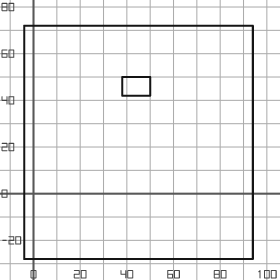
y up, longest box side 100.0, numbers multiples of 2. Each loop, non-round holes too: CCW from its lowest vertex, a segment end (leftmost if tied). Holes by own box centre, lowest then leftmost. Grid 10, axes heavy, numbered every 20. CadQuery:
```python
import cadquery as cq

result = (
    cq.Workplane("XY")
    .moveTo(-4.0, -28.0)
    .lineTo(94.0, -28.0)
    .lineTo(94.0, 72.0)
    .lineTo(-4.0, 72.0)
    .close()
    .moveTo(38.0, 42.0)
    .lineTo(50.0, 42.0)
    .lineTo(50.0, 50.0)
    .lineTo(38.0, 50.0)
    .close()
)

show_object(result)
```